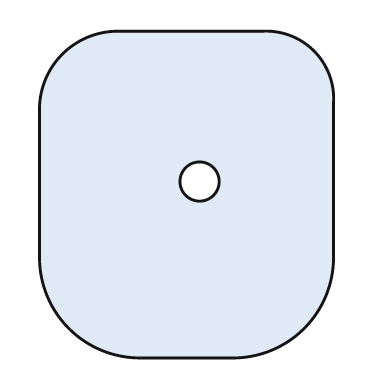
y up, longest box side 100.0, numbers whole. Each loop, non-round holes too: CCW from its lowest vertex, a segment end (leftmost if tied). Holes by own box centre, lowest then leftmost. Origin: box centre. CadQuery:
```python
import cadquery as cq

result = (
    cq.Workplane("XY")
    .moveTo(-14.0, -50.0)
    .lineTo(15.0, -50.0)
    .threePointArc((36.0, -41.0), (45.0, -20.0))
    .lineTo(45.0, 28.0)
    .threePointArc((39.0, 44.0), (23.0, 50.0))
    .lineTo(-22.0, 50.0)
    .threePointArc((-38.0, 43.0), (-45.0, 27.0))
    .lineTo(-45.0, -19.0)
    .threePointArc((-36.0, -41.0), (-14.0, -50.0))
    .close()
    .moveTo(4.0, 4.0)
    .circle(6.0)
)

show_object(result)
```